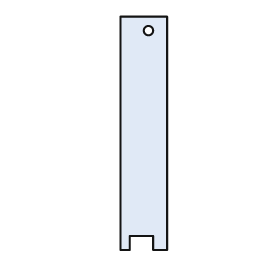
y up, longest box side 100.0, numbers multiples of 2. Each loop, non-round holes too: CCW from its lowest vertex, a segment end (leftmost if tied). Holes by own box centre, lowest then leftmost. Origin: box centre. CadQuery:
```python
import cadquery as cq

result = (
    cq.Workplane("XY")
    .moveTo(-10.0, -50.0)
    .lineTo(-6.0, -50.0)
    .lineTo(-6.0, -44.0)
    .lineTo(4.0, -44.0)
    .lineTo(4.0, -50.0)
    .lineTo(10.0, -50.0)
    .lineTo(10.0, 50.0)
    .lineTo(-10.0, 50.0)
    .close()
    .moveTo(2.0, 44.0)
    .circle(2.0)
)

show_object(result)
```